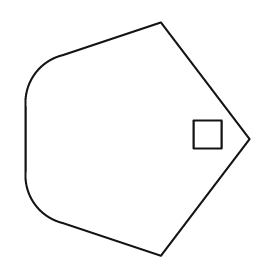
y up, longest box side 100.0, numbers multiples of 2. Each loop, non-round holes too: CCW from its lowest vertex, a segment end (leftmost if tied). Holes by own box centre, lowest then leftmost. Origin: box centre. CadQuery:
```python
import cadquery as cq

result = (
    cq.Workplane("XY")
    .moveTo(10.0, -50.0)
    .lineTo(48.0, 0.0)
    .lineTo(10.0, 50.0)
    .lineTo(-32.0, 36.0)
    .threePointArc((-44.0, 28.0), (-48.0, 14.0))
    .lineTo(-48.0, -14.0)
    .threePointArc((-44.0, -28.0), (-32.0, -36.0))
    .close()
    .moveTo(24.0, -4.0)
    .lineTo(36.0, -4.0)
    .lineTo(36.0, 8.0)
    .lineTo(24.0, 8.0)
    .close()
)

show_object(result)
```